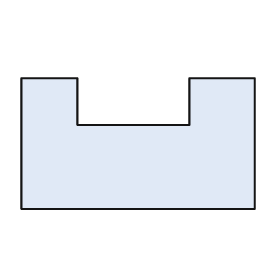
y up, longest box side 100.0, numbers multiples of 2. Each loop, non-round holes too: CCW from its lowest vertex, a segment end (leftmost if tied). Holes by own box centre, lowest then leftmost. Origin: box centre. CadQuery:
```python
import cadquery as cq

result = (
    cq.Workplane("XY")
    .moveTo(-50.0, -28.0)
    .lineTo(50.0, -28.0)
    .lineTo(50.0, 28.0)
    .lineTo(22.0, 28.0)
    .lineTo(22.0, 8.0)
    .lineTo(-26.0, 8.0)
    .lineTo(-26.0, 28.0)
    .lineTo(-50.0, 28.0)
    .close()
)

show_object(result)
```